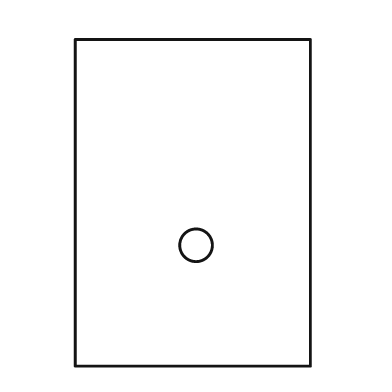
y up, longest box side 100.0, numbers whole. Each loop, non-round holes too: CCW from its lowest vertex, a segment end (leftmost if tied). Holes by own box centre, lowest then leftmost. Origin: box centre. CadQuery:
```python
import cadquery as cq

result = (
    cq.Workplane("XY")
    .moveTo(-36.0, -50.0)
    .lineTo(36.0, -50.0)
    .lineTo(36.0, 50.0)
    .lineTo(-36.0, 50.0)
    .close()
    .moveTo(1.0, -13.0)
    .circle(5.0)
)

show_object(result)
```